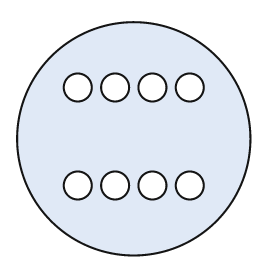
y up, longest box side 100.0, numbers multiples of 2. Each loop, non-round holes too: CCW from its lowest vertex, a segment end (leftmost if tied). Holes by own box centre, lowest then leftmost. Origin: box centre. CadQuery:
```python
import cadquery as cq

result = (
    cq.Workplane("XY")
    .moveTo(0.0, 0.0)
    .circle(50.0)
    .moveTo(-24.0, -20.0)
    .circle(6.0)
    .moveTo(-8.0, -20.0)
    .circle(6.0)
    .moveTo(8.0, -20.0)
    .circle(6.0)
    .moveTo(24.0, -20.0)
    .circle(6.0)
    .moveTo(-24.0, 22.0)
    .circle(6.0)
    .moveTo(-8.0, 22.0)
    .circle(6.0)
    .moveTo(8.0, 22.0)
    .circle(6.0)
    .moveTo(24.0, 22.0)
    .circle(6.0)
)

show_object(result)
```